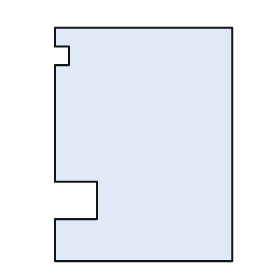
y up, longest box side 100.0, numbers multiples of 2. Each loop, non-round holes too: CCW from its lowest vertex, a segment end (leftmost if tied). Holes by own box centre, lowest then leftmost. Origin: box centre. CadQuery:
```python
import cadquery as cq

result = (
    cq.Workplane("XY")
    .moveTo(-38.0, -50.0)
    .lineTo(38.0, -50.0)
    .lineTo(38.0, 50.0)
    .lineTo(-38.0, 50.0)
    .lineTo(-38.0, 42.0)
    .lineTo(-32.0, 42.0)
    .lineTo(-32.0, 34.0)
    .lineTo(-38.0, 34.0)
    .lineTo(-38.0, -16.0)
    .lineTo(-20.0, -16.0)
    .lineTo(-20.0, -32.0)
    .lineTo(-38.0, -32.0)
    .close()
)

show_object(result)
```